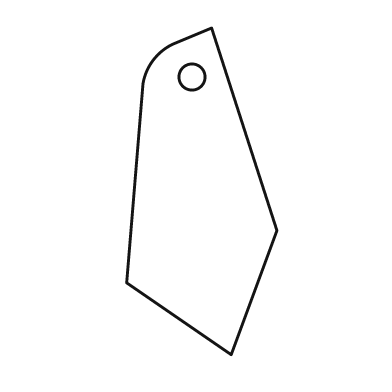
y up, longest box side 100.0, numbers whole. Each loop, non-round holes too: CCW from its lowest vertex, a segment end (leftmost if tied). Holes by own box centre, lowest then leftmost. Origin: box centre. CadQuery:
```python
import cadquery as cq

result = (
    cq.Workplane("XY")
    .moveTo(9.0, -50.0)
    .lineTo(23.0, -12.0)
    .lineTo(3.0, 50.0)
    .lineTo(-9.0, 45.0)
    .threePointArc((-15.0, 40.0), (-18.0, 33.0))
    .lineTo(-23.0, -28.0)
    .close()
    .moveTo(-3.0, 35.0)
    .circle(4.0)
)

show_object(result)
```